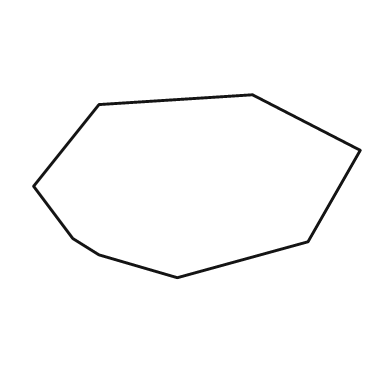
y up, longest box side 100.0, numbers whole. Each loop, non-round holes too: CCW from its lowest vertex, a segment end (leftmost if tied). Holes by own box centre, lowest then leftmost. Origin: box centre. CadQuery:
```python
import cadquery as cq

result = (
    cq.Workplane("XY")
    .moveTo(-6.0, -28.0)
    .lineTo(34.0, -17.0)
    .lineTo(50.0, 11.0)
    .lineTo(17.0, 28.0)
    .lineTo(-30.0, 25.0)
    .lineTo(-50.0, 0.0)
    .lineTo(-38.0, -16.0)
    .lineTo(-30.0, -21.0)
    .close()
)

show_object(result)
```